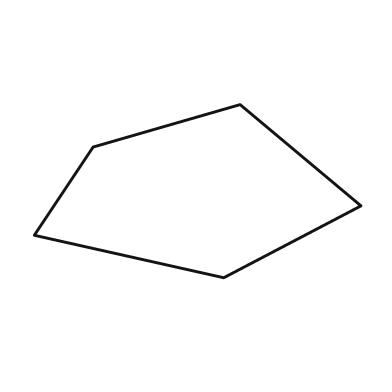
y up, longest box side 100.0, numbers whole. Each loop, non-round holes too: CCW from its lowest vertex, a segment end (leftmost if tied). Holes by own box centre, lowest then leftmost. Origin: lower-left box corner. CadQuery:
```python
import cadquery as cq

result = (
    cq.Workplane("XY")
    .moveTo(58.0, 0.0)
    .lineTo(100.0, 22.0)
    .lineTo(63.0, 53.0)
    .lineTo(18.0, 40.0)
    .lineTo(0.0, 13.0)
    .close()
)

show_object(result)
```